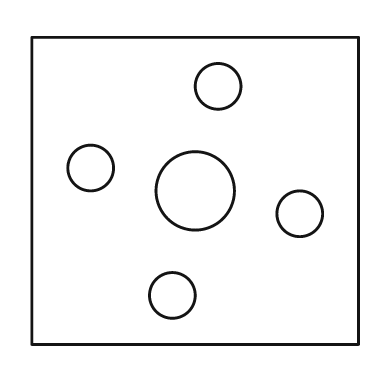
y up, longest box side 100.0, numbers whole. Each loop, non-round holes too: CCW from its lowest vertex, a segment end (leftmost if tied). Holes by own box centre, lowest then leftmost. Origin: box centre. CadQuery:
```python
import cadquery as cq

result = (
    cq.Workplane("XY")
    .moveTo(-50.0, -47.0)
    .lineTo(50.0, -47.0)
    .lineTo(50.0, 47.0)
    .lineTo(-50.0, 47.0)
    .close()
    .moveTo(-7.0, -32.0)
    .circle(7.0)
    .moveTo(32.0, -7.0)
    .circle(7.0)
    .moveTo(0.0, 0.0)
    .circle(12.0)
    .moveTo(-32.0, 7.0)
    .circle(7.0)
    .moveTo(7.0, 32.0)
    .circle(7.0)
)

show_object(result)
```